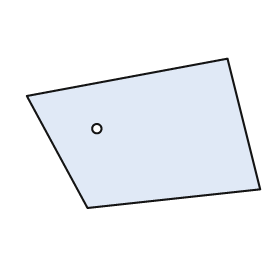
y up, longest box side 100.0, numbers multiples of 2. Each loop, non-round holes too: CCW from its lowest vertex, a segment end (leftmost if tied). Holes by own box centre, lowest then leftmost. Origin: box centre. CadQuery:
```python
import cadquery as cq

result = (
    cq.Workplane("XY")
    .moveTo(-24.0, -32.0)
    .lineTo(50.0, -24.0)
    .lineTo(36.0, 32.0)
    .lineTo(-50.0, 16.0)
    .close()
    .moveTo(-20.0, 2.0)
    .circle(2.0)
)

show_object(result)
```